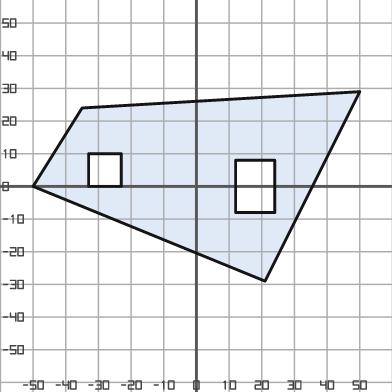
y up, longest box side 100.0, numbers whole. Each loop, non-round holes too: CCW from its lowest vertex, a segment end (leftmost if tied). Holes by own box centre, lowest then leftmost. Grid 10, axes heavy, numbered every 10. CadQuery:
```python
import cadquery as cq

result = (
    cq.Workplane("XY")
    .moveTo(21.0, -29.0)
    .lineTo(50.0, 29.0)
    .lineTo(-35.0, 24.0)
    .lineTo(-50.0, 0.0)
    .close()
    .moveTo(12.0, -8.0)
    .lineTo(24.0, -8.0)
    .lineTo(24.0, 8.0)
    .lineTo(12.0, 8.0)
    .close()
    .moveTo(-33.0, 0.0)
    .lineTo(-23.0, 0.0)
    .lineTo(-23.0, 10.0)
    .lineTo(-33.0, 10.0)
    .close()
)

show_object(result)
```